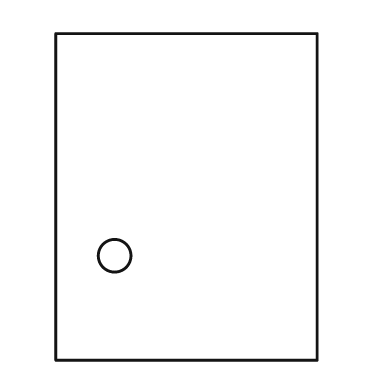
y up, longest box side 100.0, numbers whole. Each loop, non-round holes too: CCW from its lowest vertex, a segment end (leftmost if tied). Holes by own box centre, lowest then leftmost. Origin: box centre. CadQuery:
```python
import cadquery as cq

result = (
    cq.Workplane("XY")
    .moveTo(-40.0, -50.0)
    .lineTo(40.0, -50.0)
    .lineTo(40.0, 50.0)
    .lineTo(-40.0, 50.0)
    .close()
    .moveTo(-22.0, -18.0)
    .circle(5.0)
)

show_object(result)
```